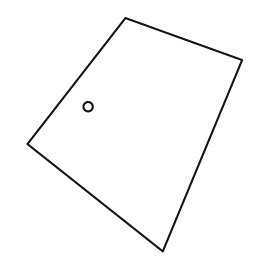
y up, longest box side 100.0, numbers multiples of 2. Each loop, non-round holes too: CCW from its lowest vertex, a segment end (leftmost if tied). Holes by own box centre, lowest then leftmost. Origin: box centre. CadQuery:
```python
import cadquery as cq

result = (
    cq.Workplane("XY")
    .moveTo(12.0, -50.0)
    .lineTo(46.0, 32.0)
    .lineTo(-4.0, 50.0)
    .lineTo(-46.0, -4.0)
    .close()
    .moveTo(-20.0, 12.0)
    .circle(2.0)
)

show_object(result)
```